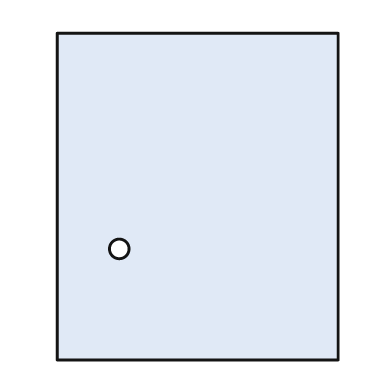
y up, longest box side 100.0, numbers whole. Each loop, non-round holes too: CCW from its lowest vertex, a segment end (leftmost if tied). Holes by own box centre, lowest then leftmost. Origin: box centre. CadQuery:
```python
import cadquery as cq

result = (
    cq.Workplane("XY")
    .moveTo(-43.0, -50.0)
    .lineTo(43.0, -50.0)
    .lineTo(43.0, 50.0)
    .lineTo(-43.0, 50.0)
    .close()
    .moveTo(-24.0, -16.0)
    .circle(3.0)
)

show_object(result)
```